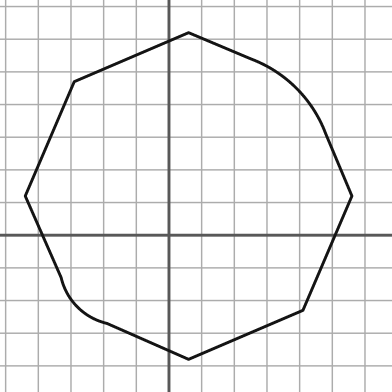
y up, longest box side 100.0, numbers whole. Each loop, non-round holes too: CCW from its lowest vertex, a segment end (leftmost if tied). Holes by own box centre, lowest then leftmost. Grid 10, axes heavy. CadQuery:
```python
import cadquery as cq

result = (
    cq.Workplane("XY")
    .moveTo(6.0, -38.0)
    .lineTo(41.0, -23.0)
    .lineTo(56.0, 12.0)
    .lineTo(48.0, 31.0)
    .threePointArc((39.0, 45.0), (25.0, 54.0))
    .lineTo(6.0, 62.0)
    .lineTo(-29.0, 47.0)
    .lineTo(-44.0, 12.0)
    .lineTo(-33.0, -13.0)
    .threePointArc((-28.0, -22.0), (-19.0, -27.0))
    .close()
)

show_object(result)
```